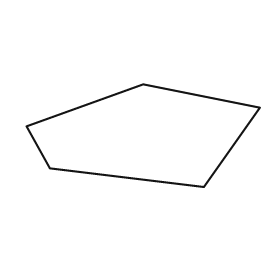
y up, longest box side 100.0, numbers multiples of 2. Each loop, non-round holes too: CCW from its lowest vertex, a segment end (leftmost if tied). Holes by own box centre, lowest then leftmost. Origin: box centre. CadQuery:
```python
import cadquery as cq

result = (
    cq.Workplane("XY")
    .moveTo(26.0, -22.0)
    .lineTo(50.0, 12.0)
    .lineTo(0.0, 22.0)
    .lineTo(-50.0, 4.0)
    .lineTo(-40.0, -14.0)
    .close()
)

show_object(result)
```